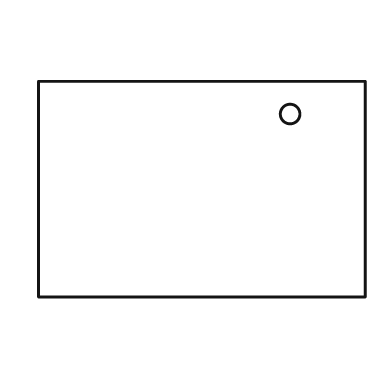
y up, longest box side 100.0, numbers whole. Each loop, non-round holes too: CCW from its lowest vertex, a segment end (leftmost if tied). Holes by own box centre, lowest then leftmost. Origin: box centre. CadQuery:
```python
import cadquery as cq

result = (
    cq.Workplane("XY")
    .moveTo(-50.0, -33.0)
    .lineTo(50.0, -33.0)
    .lineTo(50.0, 33.0)
    .lineTo(-50.0, 33.0)
    .close()
    .moveTo(27.0, 23.0)
    .circle(3.0)
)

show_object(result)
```